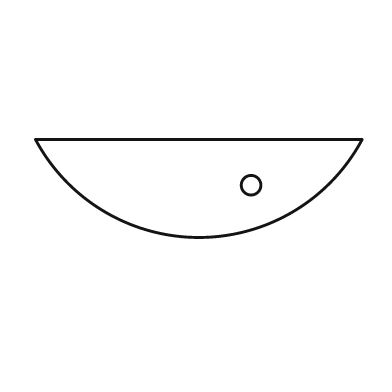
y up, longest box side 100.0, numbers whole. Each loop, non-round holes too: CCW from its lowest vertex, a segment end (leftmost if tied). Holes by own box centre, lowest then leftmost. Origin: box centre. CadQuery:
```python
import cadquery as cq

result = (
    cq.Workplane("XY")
    .moveTo(-50.0, 15.0)
    .threePointArc((0.0, -15.0), (50.0, 15.0))
    .close()
    .moveTo(16.0, 1.0)
    .circle(3.0)
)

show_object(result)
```